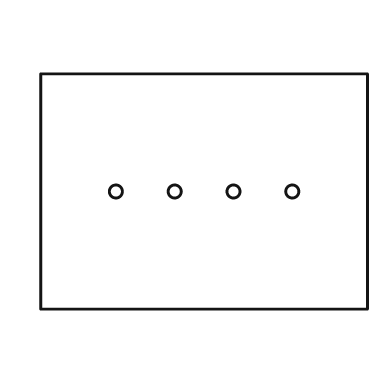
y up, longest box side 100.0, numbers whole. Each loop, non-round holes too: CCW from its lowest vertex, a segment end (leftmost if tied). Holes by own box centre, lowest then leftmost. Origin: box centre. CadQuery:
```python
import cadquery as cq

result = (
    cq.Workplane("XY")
    .moveTo(-50.0, -36.0)
    .lineTo(50.0, -36.0)
    .lineTo(50.0, 36.0)
    .lineTo(-50.0, 36.0)
    .close()
    .moveTo(-27.0, 0.0)
    .circle(2.0)
    .moveTo(-9.0, 0.0)
    .circle(2.0)
    .moveTo(9.0, 0.0)
    .circle(2.0)
    .moveTo(27.0, 0.0)
    .circle(2.0)
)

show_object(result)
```